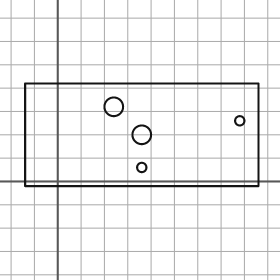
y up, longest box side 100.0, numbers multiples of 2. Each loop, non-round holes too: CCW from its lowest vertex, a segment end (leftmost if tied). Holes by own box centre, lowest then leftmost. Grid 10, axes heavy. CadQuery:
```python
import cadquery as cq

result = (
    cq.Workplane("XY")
    .moveTo(-14.0, -2.0)
    .lineTo(86.0, -2.0)
    .lineTo(86.0, 42.0)
    .lineTo(-14.0, 42.0)
    .close()
    .moveTo(36.0, 6.0)
    .circle(2.0)
    .moveTo(36.0, 20.0)
    .circle(4.0)
    .moveTo(78.0, 26.0)
    .circle(2.0)
    .moveTo(24.0, 32.0)
    .circle(4.0)
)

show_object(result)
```